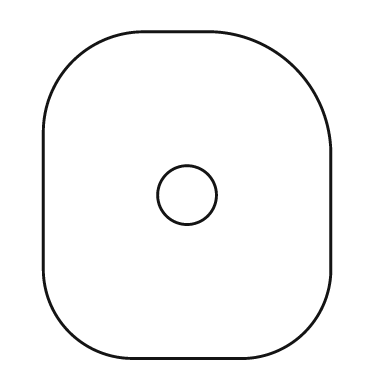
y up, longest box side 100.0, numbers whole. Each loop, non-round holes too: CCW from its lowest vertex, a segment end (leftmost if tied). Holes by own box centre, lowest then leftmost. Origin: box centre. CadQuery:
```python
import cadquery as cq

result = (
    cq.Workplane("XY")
    .moveTo(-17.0, -50.0)
    .lineTo(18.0, -50.0)
    .threePointArc((36.0, -42.0), (44.0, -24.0))
    .lineTo(44.0, 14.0)
    .threePointArc((33.0, 39.0), (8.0, 50.0))
    .lineTo(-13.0, 50.0)
    .threePointArc((-35.0, 41.0), (-44.0, 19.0))
    .lineTo(-44.0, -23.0)
    .threePointArc((-36.0, -42.0), (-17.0, -50.0))
    .close()
    .moveTo(0.0, 0.0)
    .circle(9.0)
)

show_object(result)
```